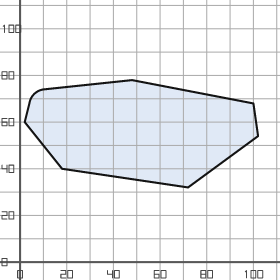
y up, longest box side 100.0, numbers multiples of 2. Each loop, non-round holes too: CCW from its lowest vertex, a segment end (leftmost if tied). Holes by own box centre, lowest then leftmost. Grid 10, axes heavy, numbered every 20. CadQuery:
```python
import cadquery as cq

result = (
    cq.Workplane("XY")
    .moveTo(72.0, 32.0)
    .lineTo(102.0, 54.0)
    .lineTo(100.0, 68.0)
    .lineTo(48.0, 78.0)
    .lineTo(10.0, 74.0)
    .threePointArc((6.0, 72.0), (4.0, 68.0))
    .lineTo(2.0, 60.0)
    .lineTo(18.0, 40.0)
    .close()
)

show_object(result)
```